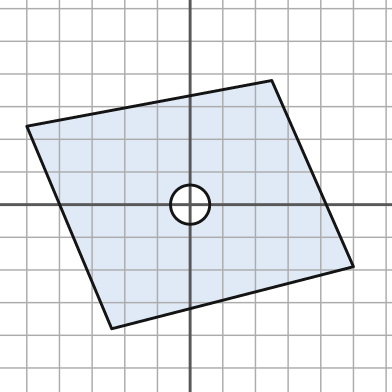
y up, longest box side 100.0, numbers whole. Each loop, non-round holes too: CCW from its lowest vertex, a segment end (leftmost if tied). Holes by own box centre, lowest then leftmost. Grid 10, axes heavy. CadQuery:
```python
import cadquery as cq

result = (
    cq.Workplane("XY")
    .moveTo(-24.0, -38.0)
    .lineTo(50.0, -19.0)
    .lineTo(25.0, 38.0)
    .lineTo(-50.0, 24.0)
    .close()
    .moveTo(0.0, 0.0)
    .circle(6.0)
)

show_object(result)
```